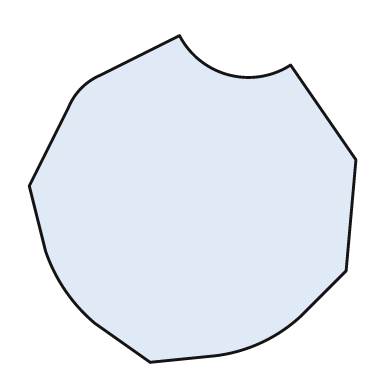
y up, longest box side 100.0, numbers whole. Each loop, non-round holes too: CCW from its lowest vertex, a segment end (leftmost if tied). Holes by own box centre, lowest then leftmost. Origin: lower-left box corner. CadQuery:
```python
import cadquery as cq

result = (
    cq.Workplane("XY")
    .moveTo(37.0, 0.0)
    .lineTo(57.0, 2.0)
    .threePointArc((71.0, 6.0), (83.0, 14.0))
    .lineTo(97.0, 28.0)
    .lineTo(100.0, 62.0)
    .lineTo(80.0, 91.0)
    .threePointArc((61.0, 88.0), (46.0, 100.0))
    .lineTo(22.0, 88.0)
    .threePointArc((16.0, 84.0), (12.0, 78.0))
    .lineTo(0.0, 54.0)
    .lineTo(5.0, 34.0)
    .threePointArc((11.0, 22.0), (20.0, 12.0))
    .close()
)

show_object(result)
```